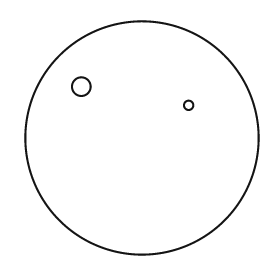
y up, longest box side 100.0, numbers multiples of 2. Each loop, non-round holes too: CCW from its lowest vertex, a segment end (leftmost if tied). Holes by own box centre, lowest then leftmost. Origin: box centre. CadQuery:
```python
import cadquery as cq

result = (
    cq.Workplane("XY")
    .moveTo(0.0, 0.0)
    .circle(50.0)
    .moveTo(20.0, 14.0)
    .circle(2.0)
    .moveTo(-26.0, 22.0)
    .circle(4.0)
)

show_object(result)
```